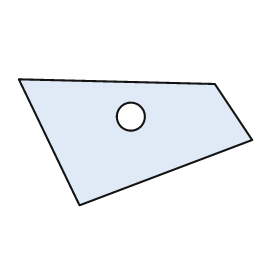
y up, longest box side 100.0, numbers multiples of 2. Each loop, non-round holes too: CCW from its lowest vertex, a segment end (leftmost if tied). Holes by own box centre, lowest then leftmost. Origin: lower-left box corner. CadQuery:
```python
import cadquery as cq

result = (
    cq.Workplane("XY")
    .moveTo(26.0, 0.0)
    .lineTo(100.0, 28.0)
    .lineTo(84.0, 52.0)
    .lineTo(0.0, 54.0)
    .close()
    .moveTo(48.0, 38.0)
    .circle(6.0)
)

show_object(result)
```